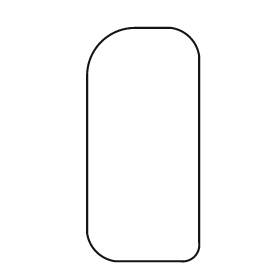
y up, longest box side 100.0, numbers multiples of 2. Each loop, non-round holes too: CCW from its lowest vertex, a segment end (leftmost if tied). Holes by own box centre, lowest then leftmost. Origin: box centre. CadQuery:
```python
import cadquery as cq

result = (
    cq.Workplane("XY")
    .moveTo(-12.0, -50.0)
    .lineTo(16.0, -50.0)
    .threePointArc((22.0, -48.0), (24.0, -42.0))
    .lineTo(24.0, 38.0)
    .threePointArc((20.0, 46.0), (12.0, 50.0))
    .lineTo(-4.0, 50.0)
    .threePointArc((-18.0, 44.0), (-24.0, 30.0))
    .lineTo(-24.0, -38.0)
    .threePointArc((-20.0, -46.0), (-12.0, -50.0))
    .close()
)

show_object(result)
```